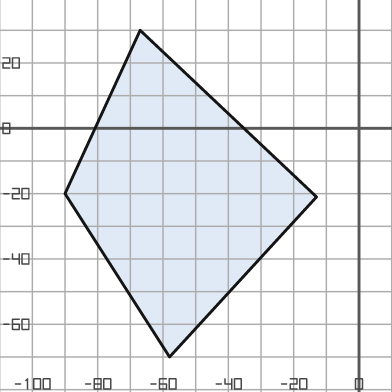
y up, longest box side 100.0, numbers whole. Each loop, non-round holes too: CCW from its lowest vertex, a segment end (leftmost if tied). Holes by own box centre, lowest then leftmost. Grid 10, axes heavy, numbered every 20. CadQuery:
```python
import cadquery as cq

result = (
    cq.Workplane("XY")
    .moveTo(-58.0, -70.0)
    .lineTo(-13.0, -21.0)
    .lineTo(-67.0, 30.0)
    .lineTo(-90.0, -20.0)
    .close()
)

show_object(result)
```